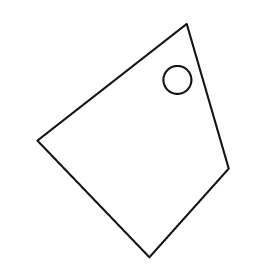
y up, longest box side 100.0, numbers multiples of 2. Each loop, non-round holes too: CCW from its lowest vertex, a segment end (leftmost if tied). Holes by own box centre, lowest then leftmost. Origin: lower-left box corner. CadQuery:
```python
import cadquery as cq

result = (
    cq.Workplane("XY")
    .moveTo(48.0, 0.0)
    .lineTo(82.0, 38.0)
    .lineTo(64.0, 100.0)
    .lineTo(0.0, 50.0)
    .close()
    .moveTo(60.0, 76.0)
    .circle(6.0)
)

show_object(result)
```